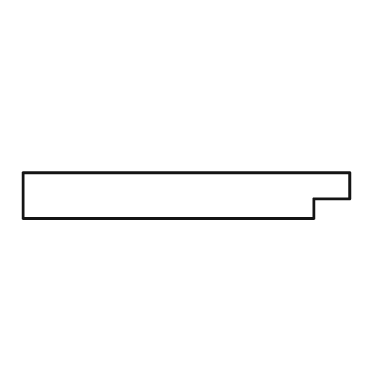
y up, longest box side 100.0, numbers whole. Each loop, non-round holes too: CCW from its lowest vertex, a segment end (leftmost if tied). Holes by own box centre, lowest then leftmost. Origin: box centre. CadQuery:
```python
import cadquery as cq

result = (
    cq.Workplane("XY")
    .moveTo(-50.0, -7.0)
    .lineTo(39.0, -7.0)
    .lineTo(39.0, -1.0)
    .lineTo(50.0, -1.0)
    .lineTo(50.0, 7.0)
    .lineTo(-50.0, 7.0)
    .close()
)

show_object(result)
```